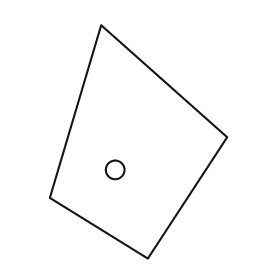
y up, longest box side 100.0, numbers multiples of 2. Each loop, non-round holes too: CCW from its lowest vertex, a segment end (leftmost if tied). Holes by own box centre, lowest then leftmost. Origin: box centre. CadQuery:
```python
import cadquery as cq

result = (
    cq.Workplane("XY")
    .moveTo(4.0, -50.0)
    .lineTo(38.0, 2.0)
    .lineTo(-16.0, 50.0)
    .lineTo(-38.0, -24.0)
    .close()
    .moveTo(-10.0, -12.0)
    .circle(4.0)
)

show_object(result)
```